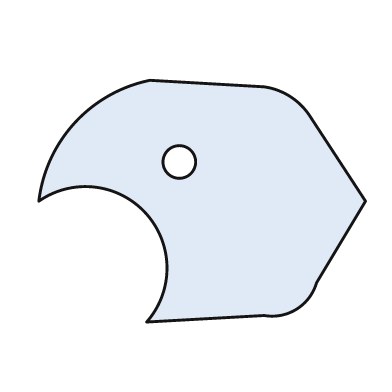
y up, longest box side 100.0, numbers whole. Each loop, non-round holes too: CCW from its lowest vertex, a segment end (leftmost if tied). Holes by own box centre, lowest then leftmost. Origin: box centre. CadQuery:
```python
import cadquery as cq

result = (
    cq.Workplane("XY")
    .moveTo(-17.0, -37.0)
    .lineTo(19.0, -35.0)
    .threePointArc((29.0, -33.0), (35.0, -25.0))
    .lineTo(50.0, 0.0)
    .lineTo(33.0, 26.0)
    .threePointArc((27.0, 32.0), (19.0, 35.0))
    .lineTo(-16.0, 37.0)
    .threePointArc((-39.0, 24.0), (-50.0, 0.0))
    .threePointArc((-17.0, -4.0), (-17.0, -37.0))
    .close()
    .moveTo(-7.0, 12.0)
    .circle(5.0)
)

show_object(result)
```